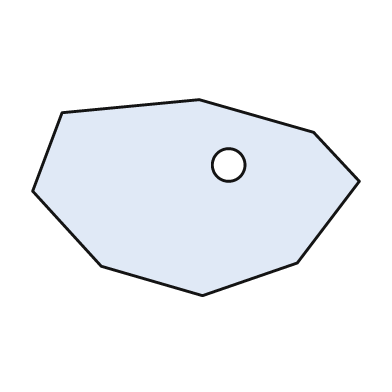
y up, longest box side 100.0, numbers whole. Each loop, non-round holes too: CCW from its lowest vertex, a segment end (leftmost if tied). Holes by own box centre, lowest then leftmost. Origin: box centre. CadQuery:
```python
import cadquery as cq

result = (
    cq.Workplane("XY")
    .moveTo(2.0, -30.0)
    .lineTo(31.0, -20.0)
    .lineTo(50.0, 5.0)
    .lineTo(36.0, 20.0)
    .lineTo(1.0, 30.0)
    .lineTo(-41.0, 26.0)
    .lineTo(-50.0, 2.0)
    .lineTo(-29.0, -21.0)
    .close()
    .moveTo(10.0, 10.0)
    .circle(5.0)
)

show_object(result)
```